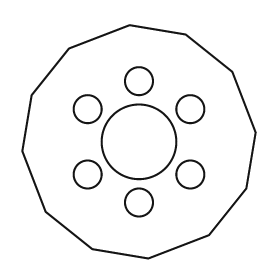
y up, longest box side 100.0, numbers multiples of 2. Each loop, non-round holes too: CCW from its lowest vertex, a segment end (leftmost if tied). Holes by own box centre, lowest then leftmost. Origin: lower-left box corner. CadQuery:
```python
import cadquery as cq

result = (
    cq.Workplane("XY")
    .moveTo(54.0, 0.0)
    .lineTo(80.0, 10.0)
    .lineTo(96.0, 30.0)
    .lineTo(100.0, 54.0)
    .lineTo(90.0, 80.0)
    .lineTo(70.0, 96.0)
    .lineTo(46.0, 100.0)
    .lineTo(20.0, 90.0)
    .lineTo(4.0, 70.0)
    .lineTo(0.0, 46.0)
    .lineTo(10.0, 20.0)
    .lineTo(30.0, 4.0)
    .close()
    .moveTo(50.0, 24.0)
    .circle(6.0)
    .moveTo(28.0, 36.0)
    .circle(6.0)
    .moveTo(72.0, 36.0)
    .circle(6.0)
    .moveTo(50.0, 50.0)
    .circle(16.0)
    .moveTo(28.0, 64.0)
    .circle(6.0)
    .moveTo(72.0, 64.0)
    .circle(6.0)
    .moveTo(50.0, 76.0)
    .circle(6.0)
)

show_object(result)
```